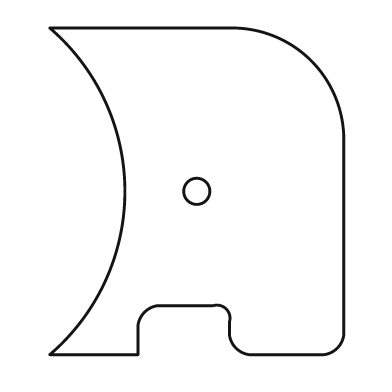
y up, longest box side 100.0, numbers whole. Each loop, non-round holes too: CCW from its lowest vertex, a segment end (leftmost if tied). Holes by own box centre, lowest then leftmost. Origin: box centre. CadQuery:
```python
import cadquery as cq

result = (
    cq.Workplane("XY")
    .moveTo(-45.0, -50.0)
    .lineTo(-18.0, -50.0)
    .lineTo(-18.0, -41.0)
    .threePointArc((-16.0, -37.0), (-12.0, -35.0))
    .lineTo(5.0, -35.0)
    .threePointArc((9.0, -36.0), (10.0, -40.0))
    .lineTo(10.0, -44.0)
    .threePointArc((12.0, -48.0), (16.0, -50.0))
    .lineTo(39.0, -50.0)
    .threePointArc((43.0, -48.0), (45.0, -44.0))
    .lineTo(45.0, 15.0)
    .threePointArc((35.0, 40.0), (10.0, 50.0))
    .lineTo(-45.0, 50.0)
    .threePointArc((-22.0, 0.0), (-45.0, -50.0))
    .close()
    .moveTo(0.0, 0.0)
    .circle(4.0)
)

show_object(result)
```